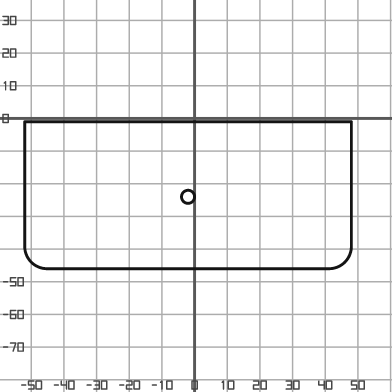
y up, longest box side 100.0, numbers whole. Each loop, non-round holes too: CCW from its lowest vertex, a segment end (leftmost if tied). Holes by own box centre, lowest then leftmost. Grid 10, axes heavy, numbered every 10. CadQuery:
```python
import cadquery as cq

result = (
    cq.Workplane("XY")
    .moveTo(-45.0, -46.0)
    .lineTo(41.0, -46.0)
    .threePointArc((46.0, -44.0), (48.0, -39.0))
    .lineTo(48.0, -1.0)
    .lineTo(-52.0, -1.0)
    .lineTo(-52.0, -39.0)
    .threePointArc((-50.0, -44.0), (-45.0, -46.0))
    .close()
    .moveTo(-2.0, -24.0)
    .circle(2.0)
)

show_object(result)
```